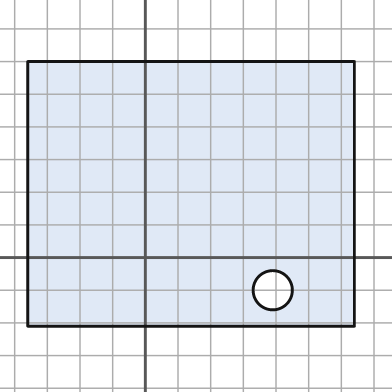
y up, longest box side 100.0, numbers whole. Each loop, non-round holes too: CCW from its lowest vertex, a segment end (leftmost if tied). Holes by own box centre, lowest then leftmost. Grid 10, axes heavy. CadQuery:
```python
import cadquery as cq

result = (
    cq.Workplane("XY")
    .moveTo(-36.0, -21.0)
    .lineTo(64.0, -21.0)
    .lineTo(64.0, 60.0)
    .lineTo(-36.0, 60.0)
    .close()
    .moveTo(39.0, -10.0)
    .circle(6.0)
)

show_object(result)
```